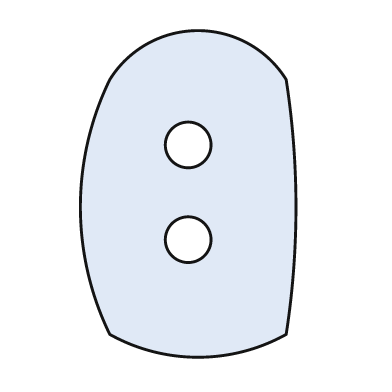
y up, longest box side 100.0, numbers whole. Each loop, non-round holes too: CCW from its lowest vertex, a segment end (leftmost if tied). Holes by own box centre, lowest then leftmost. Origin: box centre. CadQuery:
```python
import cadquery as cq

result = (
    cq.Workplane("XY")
    .moveTo(-24.0, -43.0)
    .threePointArc((3.0, -50.0), (30.0, -43.0))
    .threePointArc((33.0, -4.0), (30.0, 35.0))
    .threePointArc((3.0, 50.0), (-24.0, 35.0))
    .threePointArc((-33.0, -4.0), (-24.0, -43.0))
    .close()
    .moveTo(0.0, -14.0)
    .circle(7.0)
    .moveTo(0.0, 15.0)
    .circle(7.0)
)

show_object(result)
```